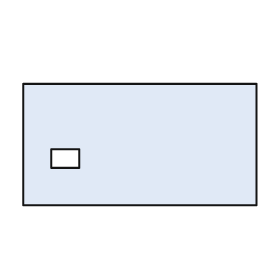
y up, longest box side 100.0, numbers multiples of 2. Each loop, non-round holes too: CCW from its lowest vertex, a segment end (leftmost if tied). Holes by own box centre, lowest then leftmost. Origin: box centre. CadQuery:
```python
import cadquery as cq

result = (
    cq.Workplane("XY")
    .moveTo(-50.0, -26.0)
    .lineTo(50.0, -26.0)
    .lineTo(50.0, 26.0)
    .lineTo(-50.0, 26.0)
    .close()
    .moveTo(-38.0, -10.0)
    .lineTo(-26.0, -10.0)
    .lineTo(-26.0, -2.0)
    .lineTo(-38.0, -2.0)
    .close()
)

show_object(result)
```